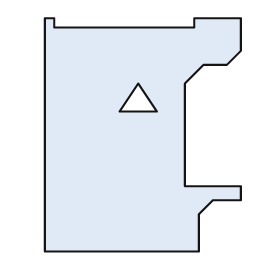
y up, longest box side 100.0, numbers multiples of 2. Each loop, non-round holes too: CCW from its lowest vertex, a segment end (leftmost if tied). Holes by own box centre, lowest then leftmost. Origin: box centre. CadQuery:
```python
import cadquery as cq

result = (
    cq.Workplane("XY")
    .moveTo(-42.0, -50.0)
    .lineTo(24.0, -50.0)
    .lineTo(24.0, -34.0)
    .lineTo(30.0, -28.0)
    .lineTo(42.0, -28.0)
    .lineTo(42.0, -22.0)
    .lineTo(18.0, -22.0)
    .lineTo(18.0, 22.0)
    .lineTo(26.0, 30.0)
    .lineTo(36.0, 30.0)
    .lineTo(42.0, 36.0)
    .lineTo(42.0, 50.0)
    .lineTo(22.0, 50.0)
    .lineTo(22.0, 46.0)
    .lineTo(-38.0, 46.0)
    .lineTo(-38.0, 50.0)
    .lineTo(-42.0, 50.0)
    .close()
    .moveTo(-10.0, 10.0)
    .lineTo(6.0, 10.0)
    .lineTo(-2.0, 22.0)
    .close()
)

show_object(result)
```